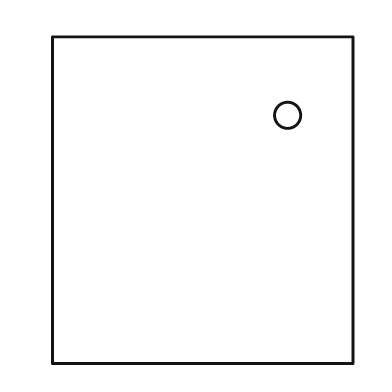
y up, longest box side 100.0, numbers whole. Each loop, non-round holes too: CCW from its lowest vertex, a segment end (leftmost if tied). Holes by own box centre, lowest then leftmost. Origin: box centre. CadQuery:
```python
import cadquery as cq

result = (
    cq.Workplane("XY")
    .moveTo(-46.0, -50.0)
    .lineTo(46.0, -50.0)
    .lineTo(46.0, 50.0)
    .lineTo(-46.0, 50.0)
    .close()
    .moveTo(26.0, 26.0)
    .circle(4.0)
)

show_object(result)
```